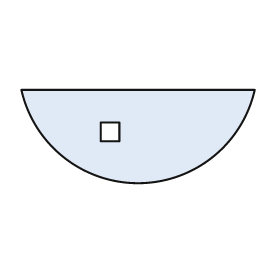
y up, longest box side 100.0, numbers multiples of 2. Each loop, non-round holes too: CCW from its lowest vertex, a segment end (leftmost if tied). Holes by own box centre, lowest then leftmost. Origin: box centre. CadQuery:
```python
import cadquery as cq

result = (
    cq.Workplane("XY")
    .moveTo(-50.0, 20.0)
    .threePointArc((0.0, -20.0), (50.0, 20.0))
    .close()
    .moveTo(-16.0, -2.0)
    .lineTo(-8.0, -2.0)
    .lineTo(-8.0, 6.0)
    .lineTo(-16.0, 6.0)
    .close()
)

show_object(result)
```